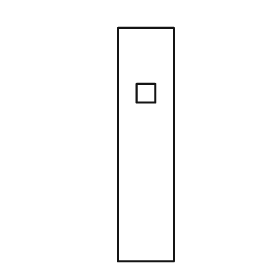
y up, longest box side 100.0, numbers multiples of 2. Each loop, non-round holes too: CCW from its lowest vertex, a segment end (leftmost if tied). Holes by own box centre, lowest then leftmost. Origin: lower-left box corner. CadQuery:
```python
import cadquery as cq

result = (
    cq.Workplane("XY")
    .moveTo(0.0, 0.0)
    .lineTo(24.0, 0.0)
    .lineTo(24.0, 100.0)
    .lineTo(0.0, 100.0)
    .close()
    .moveTo(8.0, 68.0)
    .lineTo(16.0, 68.0)
    .lineTo(16.0, 76.0)
    .lineTo(8.0, 76.0)
    .close()
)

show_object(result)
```